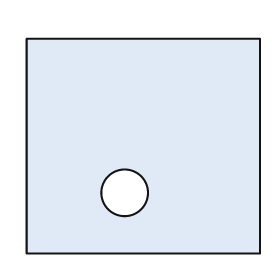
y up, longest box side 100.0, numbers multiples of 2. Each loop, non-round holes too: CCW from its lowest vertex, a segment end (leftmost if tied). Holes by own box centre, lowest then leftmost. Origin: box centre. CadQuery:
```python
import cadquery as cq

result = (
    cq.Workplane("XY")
    .moveTo(-50.0, -46.0)
    .lineTo(50.0, -46.0)
    .lineTo(50.0, 46.0)
    .lineTo(-50.0, 46.0)
    .close()
    .moveTo(-8.0, -20.0)
    .circle(10.0)
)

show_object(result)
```